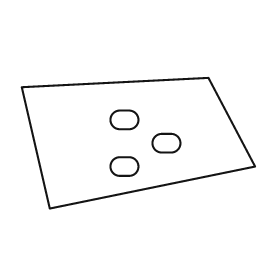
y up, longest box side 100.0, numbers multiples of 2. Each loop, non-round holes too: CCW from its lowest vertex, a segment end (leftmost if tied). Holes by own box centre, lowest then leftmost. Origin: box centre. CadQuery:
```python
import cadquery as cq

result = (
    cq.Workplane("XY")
    .moveTo(-38.0, -28.0)
    .lineTo(50.0, -10.0)
    .lineTo(30.0, 28.0)
    .lineTo(-50.0, 24.0)
    .close()
    .moveTo(-8.0, -14.0)
    .lineTo(-4.0, -14.0)
    .threePointArc((0.0, -10.0), (-4.0, -6.0))
    .lineTo(-8.0, -6.0)
    .threePointArc((-12.0, -10.0), (-8.0, -14.0))
    .close()
    .moveTo(10.0, -4.0)
    .lineTo(14.0, -4.0)
    .threePointArc((18.0, 0.0), (14.0, 4.0))
    .lineTo(10.0, 4.0)
    .threePointArc((6.0, 0.0), (10.0, -4.0))
    .close()
    .moveTo(-8.0, 6.0)
    .lineTo(-4.0, 6.0)
    .threePointArc((0.0, 10.0), (-4.0, 14.0))
    .lineTo(-8.0, 14.0)
    .threePointArc((-12.0, 10.0), (-8.0, 6.0))
    .close()
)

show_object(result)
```